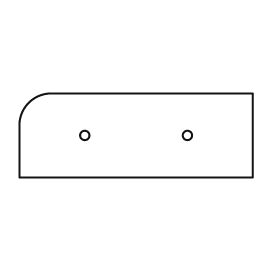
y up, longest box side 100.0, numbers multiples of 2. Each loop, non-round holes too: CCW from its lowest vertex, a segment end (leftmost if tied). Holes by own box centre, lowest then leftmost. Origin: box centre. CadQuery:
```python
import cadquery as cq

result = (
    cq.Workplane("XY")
    .moveTo(-50.0, -18.0)
    .lineTo(50.0, -18.0)
    .lineTo(50.0, 18.0)
    .lineTo(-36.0, 18.0)
    .threePointArc((-46.0, 14.0), (-50.0, 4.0))
    .close()
    .moveTo(-22.0, 0.0)
    .circle(2.0)
    .moveTo(22.0, 0.0)
    .circle(2.0)
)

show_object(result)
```